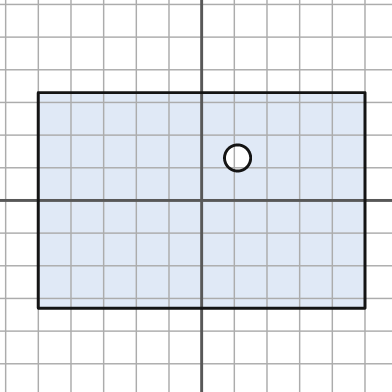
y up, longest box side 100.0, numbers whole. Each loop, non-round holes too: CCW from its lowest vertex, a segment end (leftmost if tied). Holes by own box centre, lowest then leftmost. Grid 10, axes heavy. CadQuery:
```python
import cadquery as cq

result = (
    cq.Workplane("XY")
    .moveTo(-50.0, -33.0)
    .lineTo(50.0, -33.0)
    .lineTo(50.0, 33.0)
    .lineTo(-50.0, 33.0)
    .close()
    .moveTo(11.0, 13.0)
    .circle(4.0)
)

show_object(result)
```